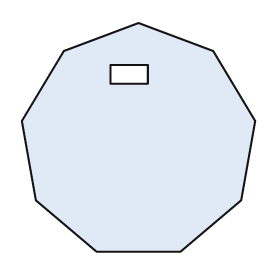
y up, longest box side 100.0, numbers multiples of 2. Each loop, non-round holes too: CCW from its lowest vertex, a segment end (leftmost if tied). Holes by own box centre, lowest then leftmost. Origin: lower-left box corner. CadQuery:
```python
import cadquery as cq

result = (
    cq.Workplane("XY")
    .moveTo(32.0, 0.0)
    .lineTo(68.0, 0.0)
    .lineTo(94.0, 22.0)
    .lineTo(100.0, 56.0)
    .lineTo(82.0, 86.0)
    .lineTo(50.0, 98.0)
    .lineTo(18.0, 86.0)
    .lineTo(0.0, 56.0)
    .lineTo(6.0, 22.0)
    .close()
    .moveTo(38.0, 72.0)
    .lineTo(54.0, 72.0)
    .lineTo(54.0, 80.0)
    .lineTo(38.0, 80.0)
    .close()
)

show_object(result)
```